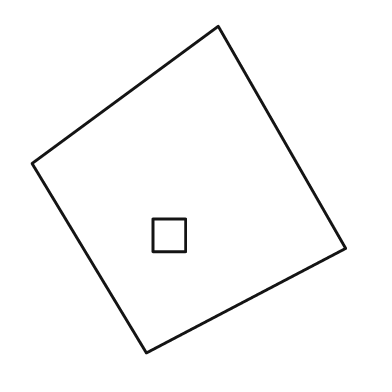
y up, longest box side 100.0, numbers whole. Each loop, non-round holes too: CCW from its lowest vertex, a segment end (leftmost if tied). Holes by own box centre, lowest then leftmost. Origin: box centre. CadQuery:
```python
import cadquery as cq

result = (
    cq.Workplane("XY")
    .moveTo(-13.0, -50.0)
    .lineTo(48.0, -18.0)
    .lineTo(9.0, 50.0)
    .lineTo(-48.0, 8.0)
    .close()
    .moveTo(-11.0, -19.0)
    .lineTo(-1.0, -19.0)
    .lineTo(-1.0, -9.0)
    .lineTo(-11.0, -9.0)
    .close()
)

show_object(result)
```